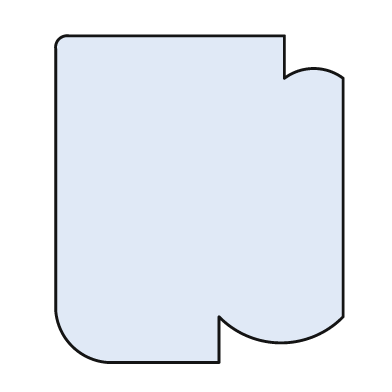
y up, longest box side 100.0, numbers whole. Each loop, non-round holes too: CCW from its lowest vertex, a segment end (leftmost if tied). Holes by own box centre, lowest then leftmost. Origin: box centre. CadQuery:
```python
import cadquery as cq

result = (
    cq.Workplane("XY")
    .moveTo(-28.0, -50.0)
    .lineTo(6.0, -50.0)
    .lineTo(6.0, -36.0)
    .threePointArc((25.0, -44.0), (44.0, -36.0))
    .lineTo(44.0, 37.0)
    .threePointArc((35.0, 40.0), (26.0, 37.0))
    .lineTo(26.0, 50.0)
    .lineTo(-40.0, 50.0)
    .threePointArc((-43.0, 49.0), (-44.0, 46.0))
    .lineTo(-44.0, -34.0)
    .threePointArc((-39.0, -45.0), (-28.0, -50.0))
    .close()
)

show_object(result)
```